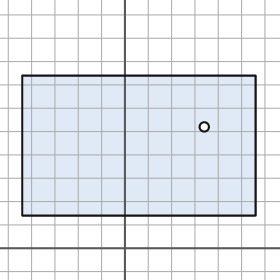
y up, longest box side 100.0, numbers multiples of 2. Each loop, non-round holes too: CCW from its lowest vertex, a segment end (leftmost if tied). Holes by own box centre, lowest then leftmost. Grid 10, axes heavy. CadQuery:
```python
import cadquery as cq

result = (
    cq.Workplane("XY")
    .moveTo(-44.0, 14.0)
    .lineTo(56.0, 14.0)
    .lineTo(56.0, 74.0)
    .lineTo(-44.0, 74.0)
    .close()
    .moveTo(34.0, 52.0)
    .circle(2.0)
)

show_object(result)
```